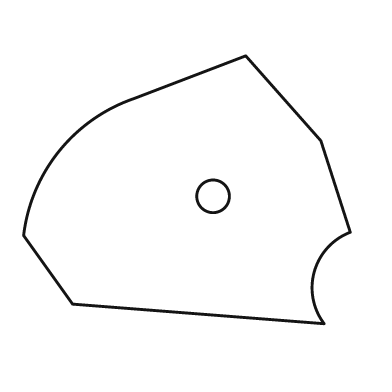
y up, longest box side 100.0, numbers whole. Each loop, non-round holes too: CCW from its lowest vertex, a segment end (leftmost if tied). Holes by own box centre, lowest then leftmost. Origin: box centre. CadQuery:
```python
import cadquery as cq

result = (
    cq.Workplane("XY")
    .moveTo(42.0, -41.0)
    .threePointArc((39.0, -25.0), (50.0, -13.0))
    .lineTo(41.0, 15.0)
    .lineTo(18.0, 41.0)
    .lineTo(-16.0, 28.0)
    .threePointArc((-39.0, 12.0), (-50.0, -14.0))
    .lineTo(-35.0, -35.0)
    .close()
    .moveTo(8.0, -2.0)
    .circle(5.0)
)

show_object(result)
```